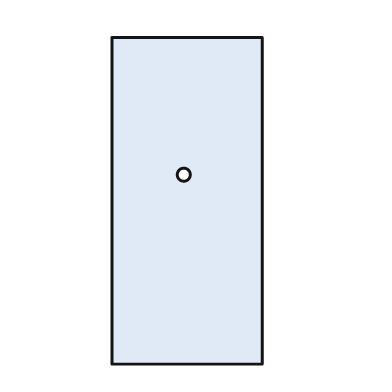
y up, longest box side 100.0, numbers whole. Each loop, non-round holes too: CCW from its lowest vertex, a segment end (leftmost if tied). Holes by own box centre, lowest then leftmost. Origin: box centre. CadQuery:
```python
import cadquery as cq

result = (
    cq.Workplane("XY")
    .moveTo(-23.0, -50.0)
    .lineTo(23.0, -50.0)
    .lineTo(23.0, 50.0)
    .lineTo(-23.0, 50.0)
    .close()
    .moveTo(-1.0, 8.0)
    .circle(2.0)
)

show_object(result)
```